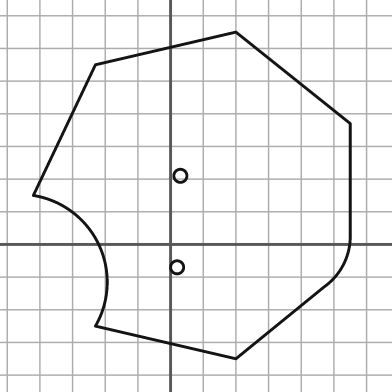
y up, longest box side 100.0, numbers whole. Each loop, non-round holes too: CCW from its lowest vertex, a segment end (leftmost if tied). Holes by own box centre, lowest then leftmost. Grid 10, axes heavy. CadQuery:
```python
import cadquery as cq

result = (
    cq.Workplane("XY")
    .moveTo(20.0, -35.0)
    .lineTo(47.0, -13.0)
    .threePointArc((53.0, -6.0), (55.0, 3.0))
    .lineTo(55.0, 37.0)
    .lineTo(20.0, 65.0)
    .lineTo(-23.0, 55.0)
    .lineTo(-42.0, 15.0)
    .threePointArc((-22.0, 0.0), (-23.0, -25.0))
    .close()
    .moveTo(2.0, -7.0)
    .circle(2.0)
    .moveTo(3.0, 21.0)
    .circle(2.0)
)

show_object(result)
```